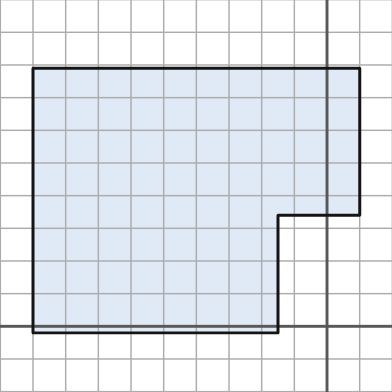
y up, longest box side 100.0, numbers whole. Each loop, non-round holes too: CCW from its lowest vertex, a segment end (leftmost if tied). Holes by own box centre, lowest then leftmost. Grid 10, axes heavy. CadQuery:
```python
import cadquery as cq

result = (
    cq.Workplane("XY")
    .moveTo(-90.0, -2.0)
    .lineTo(-15.0, -2.0)
    .lineTo(-15.0, 34.0)
    .lineTo(10.0, 34.0)
    .lineTo(10.0, 79.0)
    .lineTo(-90.0, 79.0)
    .close()
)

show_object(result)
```